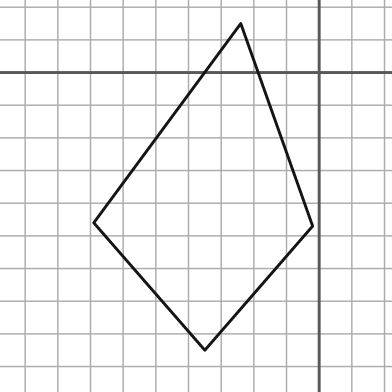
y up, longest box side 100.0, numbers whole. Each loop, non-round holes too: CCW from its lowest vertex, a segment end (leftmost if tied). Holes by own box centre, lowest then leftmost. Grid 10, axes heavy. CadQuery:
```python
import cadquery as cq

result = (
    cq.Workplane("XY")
    .moveTo(-35.0, -85.0)
    .lineTo(-2.0, -47.0)
    .lineTo(-24.0, 15.0)
    .lineTo(-69.0, -46.0)
    .close()
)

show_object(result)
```